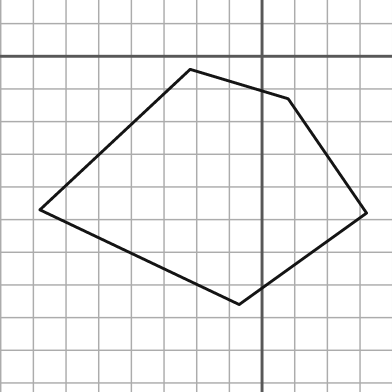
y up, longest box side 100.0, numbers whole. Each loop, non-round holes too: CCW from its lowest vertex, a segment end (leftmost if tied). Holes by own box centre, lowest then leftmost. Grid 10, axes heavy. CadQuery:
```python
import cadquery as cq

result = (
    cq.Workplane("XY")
    .moveTo(-7.0, -76.0)
    .lineTo(32.0, -48.0)
    .lineTo(8.0, -13.0)
    .lineTo(-22.0, -4.0)
    .lineTo(-68.0, -47.0)
    .close()
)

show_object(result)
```